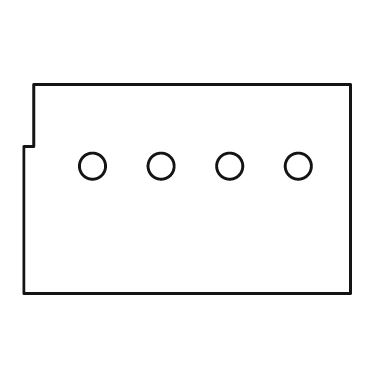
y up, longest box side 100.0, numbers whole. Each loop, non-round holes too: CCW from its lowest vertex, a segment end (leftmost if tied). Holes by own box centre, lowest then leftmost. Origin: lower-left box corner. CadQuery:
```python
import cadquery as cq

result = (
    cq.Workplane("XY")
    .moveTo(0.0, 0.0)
    .lineTo(100.0, 0.0)
    .lineTo(100.0, 64.0)
    .lineTo(3.0, 64.0)
    .lineTo(3.0, 45.0)
    .lineTo(0.0, 45.0)
    .close()
    .moveTo(21.0, 39.0)
    .circle(4.0)
    .moveTo(42.0, 39.0)
    .circle(4.0)
    .moveTo(63.0, 39.0)
    .circle(4.0)
    .moveTo(84.0, 39.0)
    .circle(4.0)
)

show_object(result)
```